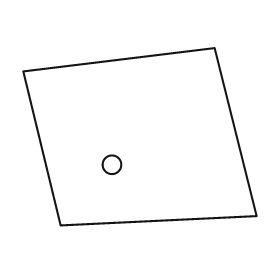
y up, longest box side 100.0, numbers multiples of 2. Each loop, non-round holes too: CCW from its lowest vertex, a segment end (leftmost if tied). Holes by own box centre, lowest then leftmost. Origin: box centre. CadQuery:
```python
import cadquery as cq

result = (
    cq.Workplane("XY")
    .moveTo(-34.0, -38.0)
    .lineTo(50.0, -34.0)
    .lineTo(32.0, 38.0)
    .lineTo(-50.0, 28.0)
    .close()
    .moveTo(-12.0, -12.0)
    .circle(4.0)
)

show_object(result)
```